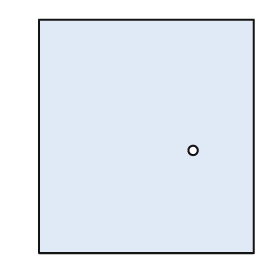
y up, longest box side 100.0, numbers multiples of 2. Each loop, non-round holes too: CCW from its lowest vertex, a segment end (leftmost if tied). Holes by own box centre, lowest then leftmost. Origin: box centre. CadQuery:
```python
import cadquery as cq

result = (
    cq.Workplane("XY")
    .moveTo(-46.0, -50.0)
    .lineTo(46.0, -50.0)
    .lineTo(46.0, 50.0)
    .lineTo(-46.0, 50.0)
    .close()
    .moveTo(20.0, -6.0)
    .circle(2.0)
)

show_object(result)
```